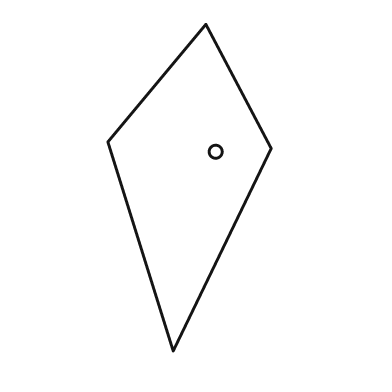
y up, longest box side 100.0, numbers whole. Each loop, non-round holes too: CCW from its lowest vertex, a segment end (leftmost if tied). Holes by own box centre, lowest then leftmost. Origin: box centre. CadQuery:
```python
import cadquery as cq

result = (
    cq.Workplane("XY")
    .moveTo(-5.0, -50.0)
    .lineTo(25.0, 12.0)
    .lineTo(5.0, 50.0)
    .lineTo(-25.0, 14.0)
    .close()
    .moveTo(8.0, 11.0)
    .circle(2.0)
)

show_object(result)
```